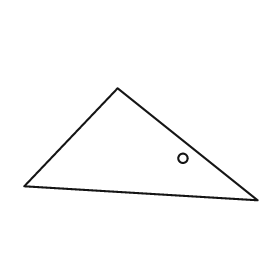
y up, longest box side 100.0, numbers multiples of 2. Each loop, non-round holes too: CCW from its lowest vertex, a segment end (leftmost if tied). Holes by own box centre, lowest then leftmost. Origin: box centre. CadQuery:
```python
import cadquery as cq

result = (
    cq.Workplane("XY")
    .moveTo(50.0, -24.0)
    .lineTo(-10.0, 24.0)
    .lineTo(-50.0, -18.0)
    .close()
    .moveTo(18.0, -6.0)
    .circle(2.0)
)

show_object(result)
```